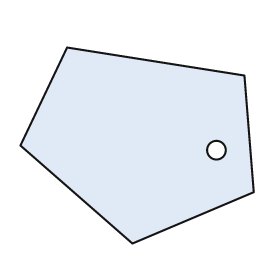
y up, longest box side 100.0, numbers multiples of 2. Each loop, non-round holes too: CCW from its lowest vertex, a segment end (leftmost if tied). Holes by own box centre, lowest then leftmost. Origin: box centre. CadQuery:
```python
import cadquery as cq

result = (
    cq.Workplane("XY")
    .moveTo(-2.0, -42.0)
    .lineTo(50.0, -20.0)
    .lineTo(46.0, 30.0)
    .lineTo(-30.0, 42.0)
    .lineTo(-50.0, 0.0)
    .close()
    .moveTo(34.0, -2.0)
    .circle(4.0)
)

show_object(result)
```